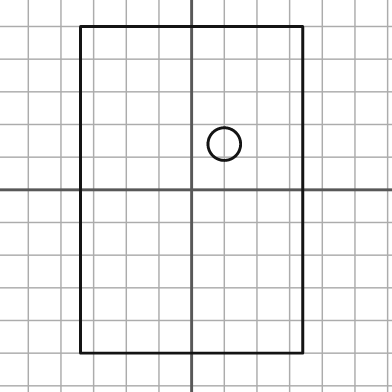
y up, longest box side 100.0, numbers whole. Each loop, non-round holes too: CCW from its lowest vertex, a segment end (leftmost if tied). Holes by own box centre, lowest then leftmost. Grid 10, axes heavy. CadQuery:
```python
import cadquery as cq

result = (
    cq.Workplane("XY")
    .moveTo(-34.0, -50.0)
    .lineTo(34.0, -50.0)
    .lineTo(34.0, 50.0)
    .lineTo(-34.0, 50.0)
    .close()
    .moveTo(10.0, 14.0)
    .circle(5.0)
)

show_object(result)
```